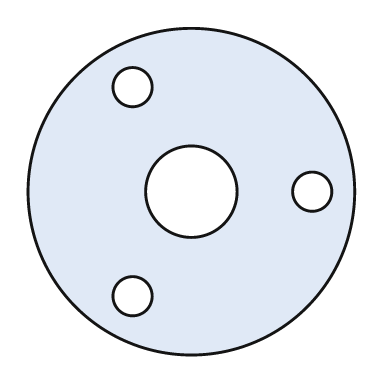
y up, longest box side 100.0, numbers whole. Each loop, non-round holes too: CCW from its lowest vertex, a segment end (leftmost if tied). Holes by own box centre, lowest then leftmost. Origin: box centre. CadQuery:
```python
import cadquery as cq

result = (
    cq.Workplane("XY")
    .moveTo(0.0, 0.0)
    .circle(50.0)
    .moveTo(-18.0, -32.0)
    .circle(6.0)
    .moveTo(0.0, 0.0)
    .circle(14.0)
    .moveTo(37.0, 0.0)
    .circle(6.0)
    .moveTo(-18.0, 32.0)
    .circle(6.0)
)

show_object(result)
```